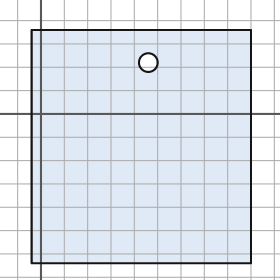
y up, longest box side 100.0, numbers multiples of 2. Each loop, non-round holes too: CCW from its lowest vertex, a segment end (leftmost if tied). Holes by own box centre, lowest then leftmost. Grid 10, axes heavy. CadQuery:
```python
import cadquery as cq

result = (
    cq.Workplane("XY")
    .moveTo(-4.0, -64.0)
    .lineTo(90.0, -64.0)
    .lineTo(90.0, 36.0)
    .lineTo(-4.0, 36.0)
    .close()
    .moveTo(46.0, 22.0)
    .circle(4.0)
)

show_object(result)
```